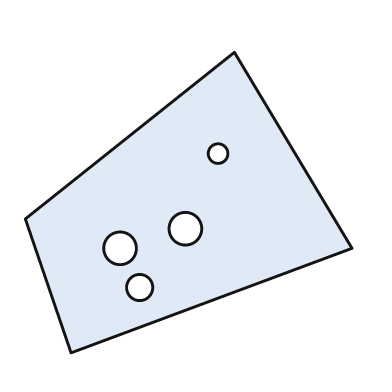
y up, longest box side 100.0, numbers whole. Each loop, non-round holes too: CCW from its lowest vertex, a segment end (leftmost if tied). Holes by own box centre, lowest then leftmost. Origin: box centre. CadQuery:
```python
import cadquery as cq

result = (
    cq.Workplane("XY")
    .moveTo(-36.0, -46.0)
    .lineTo(50.0, -14.0)
    .lineTo(14.0, 46.0)
    .lineTo(-50.0, -5.0)
    .close()
    .moveTo(-15.0, -26.0)
    .circle(4.0)
    .moveTo(-21.0, -14.0)
    .circle(5.0)
    .moveTo(-1.0, -8.0)
    .circle(5.0)
    .moveTo(9.0, 15.0)
    .circle(3.0)
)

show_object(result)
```